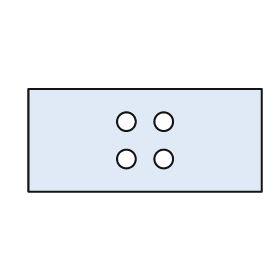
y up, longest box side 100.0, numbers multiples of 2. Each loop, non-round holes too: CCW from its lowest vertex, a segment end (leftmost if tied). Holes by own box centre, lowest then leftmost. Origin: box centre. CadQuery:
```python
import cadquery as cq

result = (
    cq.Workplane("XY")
    .moveTo(-50.0, -22.0)
    .lineTo(50.0, -22.0)
    .lineTo(50.0, 22.0)
    .lineTo(-50.0, 22.0)
    .close()
    .moveTo(-8.0, -8.0)
    .circle(4.0)
    .moveTo(8.0, -8.0)
    .circle(4.0)
    .moveTo(-8.0, 8.0)
    .circle(4.0)
    .moveTo(8.0, 8.0)
    .circle(4.0)
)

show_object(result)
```